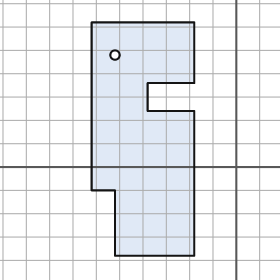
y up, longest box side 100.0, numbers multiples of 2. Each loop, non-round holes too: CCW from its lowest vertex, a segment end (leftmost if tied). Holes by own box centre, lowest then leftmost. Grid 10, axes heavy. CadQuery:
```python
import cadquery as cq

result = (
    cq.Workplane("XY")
    .moveTo(-52.0, -38.0)
    .lineTo(-18.0, -38.0)
    .lineTo(-18.0, 24.0)
    .lineTo(-38.0, 24.0)
    .lineTo(-38.0, 36.0)
    .lineTo(-18.0, 36.0)
    .lineTo(-18.0, 62.0)
    .lineTo(-62.0, 62.0)
    .lineTo(-62.0, -10.0)
    .lineTo(-52.0, -10.0)
    .close()
    .moveTo(-52.0, 48.0)
    .circle(2.0)
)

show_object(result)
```